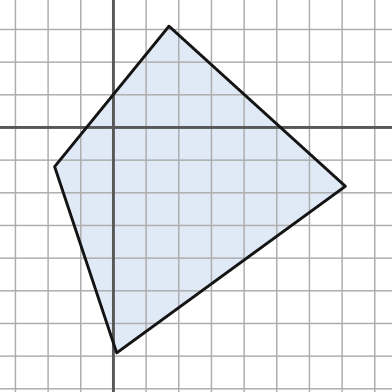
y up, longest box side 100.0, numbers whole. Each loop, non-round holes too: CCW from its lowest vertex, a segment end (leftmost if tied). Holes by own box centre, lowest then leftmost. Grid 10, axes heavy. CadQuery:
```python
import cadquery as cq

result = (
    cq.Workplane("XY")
    .moveTo(1.0, -69.0)
    .lineTo(71.0, -18.0)
    .lineTo(17.0, 31.0)
    .lineTo(-18.0, -12.0)
    .close()
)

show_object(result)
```